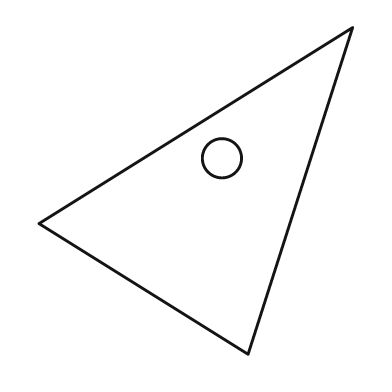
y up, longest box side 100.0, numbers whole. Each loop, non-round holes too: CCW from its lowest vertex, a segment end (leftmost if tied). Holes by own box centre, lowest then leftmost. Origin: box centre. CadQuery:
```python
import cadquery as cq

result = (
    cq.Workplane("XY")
    .moveTo(16.0, -50.0)
    .lineTo(48.0, 50.0)
    .lineTo(-48.0, -10.0)
    .close()
    .moveTo(8.0, 10.0)
    .circle(6.0)
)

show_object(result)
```